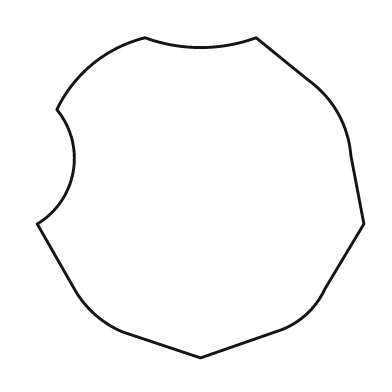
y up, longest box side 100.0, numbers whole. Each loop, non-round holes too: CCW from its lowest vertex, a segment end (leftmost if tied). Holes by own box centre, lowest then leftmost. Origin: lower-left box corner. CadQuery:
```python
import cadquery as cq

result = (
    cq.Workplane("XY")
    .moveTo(50.0, 0.0)
    .lineTo(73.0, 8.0)
    .threePointArc((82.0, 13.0), (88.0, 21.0))
    .lineTo(100.0, 41.0)
    .lineTo(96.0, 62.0)
    .threePointArc((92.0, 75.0), (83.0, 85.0))
    .lineTo(67.0, 98.0)
    .threePointArc((50.0, 95.0), (33.0, 98.0))
    .threePointArc((17.0, 90.0), (6.0, 76.0))
    .threePointArc((11.0, 57.0), (0.0, 41.0))
    .lineTo(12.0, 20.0)
    .threePointArc((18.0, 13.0), (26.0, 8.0))
    .close()
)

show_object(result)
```